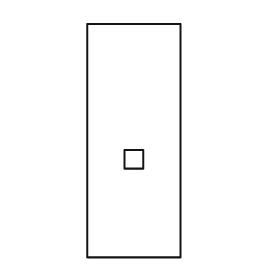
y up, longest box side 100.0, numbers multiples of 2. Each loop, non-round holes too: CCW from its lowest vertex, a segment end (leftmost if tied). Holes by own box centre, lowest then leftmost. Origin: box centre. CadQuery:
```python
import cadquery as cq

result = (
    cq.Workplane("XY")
    .moveTo(-20.0, -50.0)
    .lineTo(20.0, -50.0)
    .lineTo(20.0, 50.0)
    .lineTo(-20.0, 50.0)
    .close()
    .moveTo(-4.0, -12.0)
    .lineTo(4.0, -12.0)
    .lineTo(4.0, -4.0)
    .lineTo(-4.0, -4.0)
    .close()
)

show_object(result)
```